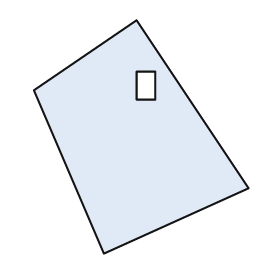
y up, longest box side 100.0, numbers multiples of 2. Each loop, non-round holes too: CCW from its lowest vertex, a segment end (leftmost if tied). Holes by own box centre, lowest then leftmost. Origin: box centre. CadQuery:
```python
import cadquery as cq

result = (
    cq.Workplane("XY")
    .moveTo(-16.0, -50.0)
    .lineTo(46.0, -22.0)
    .lineTo(-2.0, 50.0)
    .lineTo(-46.0, 20.0)
    .close()
    .moveTo(-2.0, 16.0)
    .lineTo(6.0, 16.0)
    .lineTo(6.0, 28.0)
    .lineTo(-2.0, 28.0)
    .close()
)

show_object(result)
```